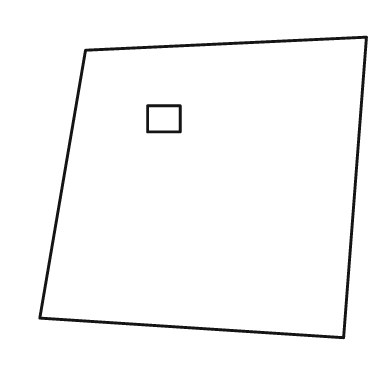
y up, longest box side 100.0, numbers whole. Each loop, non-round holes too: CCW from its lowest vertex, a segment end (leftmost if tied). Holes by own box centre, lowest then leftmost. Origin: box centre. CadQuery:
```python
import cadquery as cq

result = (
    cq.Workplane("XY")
    .moveTo(43.0, -46.0)
    .lineTo(50.0, 46.0)
    .lineTo(-36.0, 42.0)
    .lineTo(-50.0, -40.0)
    .close()
    .moveTo(-17.0, 17.0)
    .lineTo(-7.0, 17.0)
    .lineTo(-7.0, 25.0)
    .lineTo(-17.0, 25.0)
    .close()
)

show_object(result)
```